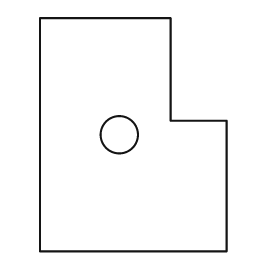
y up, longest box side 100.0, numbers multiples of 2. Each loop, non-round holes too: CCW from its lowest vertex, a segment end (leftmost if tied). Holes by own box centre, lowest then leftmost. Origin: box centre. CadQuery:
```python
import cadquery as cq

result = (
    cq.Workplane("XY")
    .moveTo(-40.0, -50.0)
    .lineTo(40.0, -50.0)
    .lineTo(40.0, 6.0)
    .lineTo(16.0, 6.0)
    .lineTo(16.0, 50.0)
    .lineTo(-40.0, 50.0)
    .close()
    .moveTo(-6.0, 0.0)
    .circle(8.0)
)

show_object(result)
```